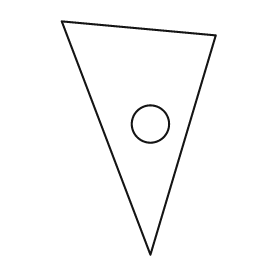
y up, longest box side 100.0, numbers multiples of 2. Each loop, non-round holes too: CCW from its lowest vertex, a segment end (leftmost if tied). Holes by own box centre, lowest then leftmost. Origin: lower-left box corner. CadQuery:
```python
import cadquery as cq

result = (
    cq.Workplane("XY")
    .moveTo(38.0, 0.0)
    .lineTo(66.0, 94.0)
    .lineTo(0.0, 100.0)
    .close()
    .moveTo(38.0, 56.0)
    .circle(8.0)
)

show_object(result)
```